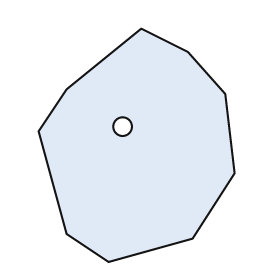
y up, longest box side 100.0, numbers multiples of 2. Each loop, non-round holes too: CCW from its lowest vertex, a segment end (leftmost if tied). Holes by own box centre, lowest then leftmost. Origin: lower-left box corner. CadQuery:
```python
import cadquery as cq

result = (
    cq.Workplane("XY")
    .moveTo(30.0, 0.0)
    .lineTo(66.0, 10.0)
    .lineTo(84.0, 38.0)
    .lineTo(80.0, 72.0)
    .lineTo(64.0, 90.0)
    .lineTo(44.0, 100.0)
    .lineTo(12.0, 74.0)
    .lineTo(0.0, 56.0)
    .lineTo(12.0, 12.0)
    .close()
    .moveTo(36.0, 58.0)
    .circle(4.0)
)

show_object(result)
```